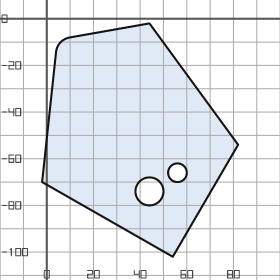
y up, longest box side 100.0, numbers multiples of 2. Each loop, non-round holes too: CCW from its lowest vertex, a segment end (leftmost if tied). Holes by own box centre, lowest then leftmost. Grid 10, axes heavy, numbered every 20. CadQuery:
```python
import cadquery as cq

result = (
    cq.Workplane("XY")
    .moveTo(54.0, -102.0)
    .lineTo(82.0, -54.0)
    .lineTo(44.0, -2.0)
    .lineTo(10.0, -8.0)
    .threePointArc((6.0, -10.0), (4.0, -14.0))
    .lineTo(-2.0, -70.0)
    .close()
    .moveTo(44.0, -74.0)
    .circle(6.0)
    .moveTo(56.0, -66.0)
    .circle(4.0)
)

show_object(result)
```